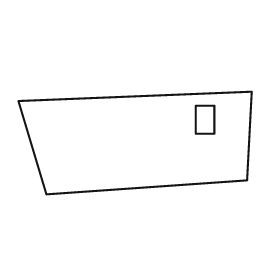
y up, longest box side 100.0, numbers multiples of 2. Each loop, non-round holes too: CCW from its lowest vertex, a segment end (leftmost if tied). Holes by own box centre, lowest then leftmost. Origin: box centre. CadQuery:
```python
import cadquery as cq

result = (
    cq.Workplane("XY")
    .moveTo(-38.0, -22.0)
    .lineTo(48.0, -16.0)
    .lineTo(50.0, 22.0)
    .lineTo(-50.0, 18.0)
    .close()
    .moveTo(26.0, 4.0)
    .lineTo(34.0, 4.0)
    .lineTo(34.0, 16.0)
    .lineTo(26.0, 16.0)
    .close()
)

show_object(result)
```